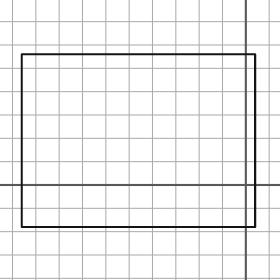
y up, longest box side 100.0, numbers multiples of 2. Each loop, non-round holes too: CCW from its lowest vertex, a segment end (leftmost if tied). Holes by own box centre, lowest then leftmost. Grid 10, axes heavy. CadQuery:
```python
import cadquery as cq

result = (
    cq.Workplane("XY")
    .moveTo(-96.0, -18.0)
    .lineTo(4.0, -18.0)
    .lineTo(4.0, 56.0)
    .lineTo(-96.0, 56.0)
    .close()
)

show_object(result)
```